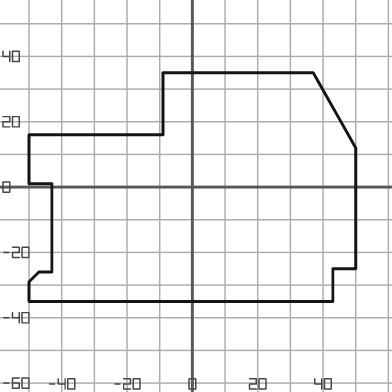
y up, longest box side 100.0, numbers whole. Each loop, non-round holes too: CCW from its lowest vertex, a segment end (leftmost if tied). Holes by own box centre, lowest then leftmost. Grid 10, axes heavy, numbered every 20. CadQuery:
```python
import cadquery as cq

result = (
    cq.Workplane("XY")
    .moveTo(-50.0, -35.0)
    .lineTo(43.0, -35.0)
    .lineTo(43.0, -25.0)
    .lineTo(50.0, -25.0)
    .lineTo(50.0, 12.0)
    .lineTo(37.0, 35.0)
    .lineTo(-9.0, 35.0)
    .lineTo(-9.0, 16.0)
    .lineTo(-50.0, 16.0)
    .lineTo(-50.0, 1.0)
    .lineTo(-43.0, 1.0)
    .lineTo(-43.0, -26.0)
    .lineTo(-47.0, -26.0)
    .lineTo(-50.0, -29.0)
    .close()
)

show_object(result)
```